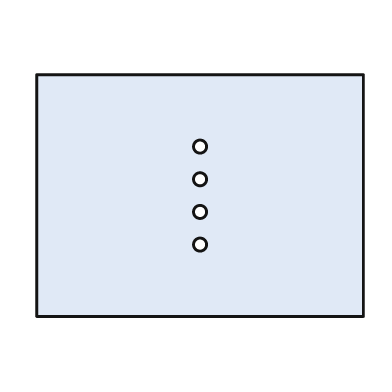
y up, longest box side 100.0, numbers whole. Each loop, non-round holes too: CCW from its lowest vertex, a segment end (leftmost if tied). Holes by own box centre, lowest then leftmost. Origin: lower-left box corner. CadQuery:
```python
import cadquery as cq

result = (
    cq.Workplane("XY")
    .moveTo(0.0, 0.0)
    .lineTo(100.0, 0.0)
    .lineTo(100.0, 74.0)
    .lineTo(0.0, 74.0)
    .close()
    .moveTo(50.0, 22.0)
    .circle(2.0)
    .moveTo(50.0, 32.0)
    .circle(2.0)
    .moveTo(50.0, 42.0)
    .circle(2.0)
    .moveTo(50.0, 52.0)
    .circle(2.0)
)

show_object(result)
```